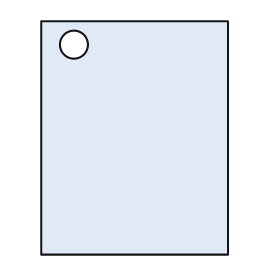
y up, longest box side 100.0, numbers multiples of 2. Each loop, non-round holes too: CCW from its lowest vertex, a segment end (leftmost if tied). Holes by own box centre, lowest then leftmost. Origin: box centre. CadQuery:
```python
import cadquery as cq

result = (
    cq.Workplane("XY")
    .moveTo(-40.0, -50.0)
    .lineTo(40.0, -50.0)
    .lineTo(40.0, 50.0)
    .lineTo(-40.0, 50.0)
    .close()
    .moveTo(-26.0, 40.0)
    .circle(6.0)
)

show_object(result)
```